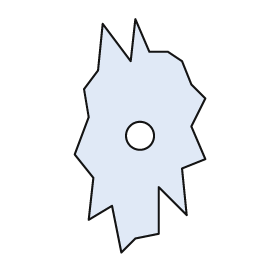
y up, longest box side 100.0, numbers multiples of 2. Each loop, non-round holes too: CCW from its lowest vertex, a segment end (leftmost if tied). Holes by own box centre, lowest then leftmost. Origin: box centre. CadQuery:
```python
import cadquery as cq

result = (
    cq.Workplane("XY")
    .moveTo(-8.0, -50.0)
    .lineTo(-2.0, -44.0)
    .lineTo(8.0, -42.0)
    .lineTo(8.0, -22.0)
    .lineTo(20.0, -34.0)
    .lineTo(18.0, -14.0)
    .lineTo(28.0, -10.0)
    .lineTo(22.0, 4.0)
    .lineTo(28.0, 16.0)
    .lineTo(22.0, 22.0)
    .lineTo(18.0, 32.0)
    .lineTo(12.0, 36.0)
    .lineTo(4.0, 36.0)
    .lineTo(-2.0, 50.0)
    .lineTo(-4.0, 32.0)
    .lineTo(-16.0, 48.0)
    .lineTo(-18.0, 28.0)
    .lineTo(-24.0, 20.0)
    .lineTo(-22.0, 8.0)
    .lineTo(-28.0, -8.0)
    .lineTo(-20.0, -18.0)
    .lineTo(-22.0, -36.0)
    .lineTo(-12.0, -30.0)
    .close()
    .moveTo(0.0, 0.0)
    .circle(6.0)
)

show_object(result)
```